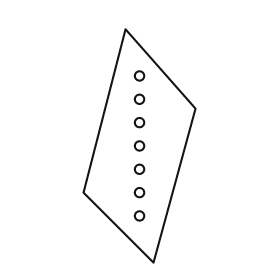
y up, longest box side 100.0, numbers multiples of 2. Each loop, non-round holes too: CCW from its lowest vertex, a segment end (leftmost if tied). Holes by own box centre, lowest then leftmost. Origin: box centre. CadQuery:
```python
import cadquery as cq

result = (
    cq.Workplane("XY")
    .moveTo(6.0, -50.0)
    .lineTo(24.0, 16.0)
    .lineTo(-6.0, 50.0)
    .lineTo(-24.0, -20.0)
    .close()
    .moveTo(0.0, -30.0)
    .circle(2.0)
    .moveTo(0.0, -20.0)
    .circle(2.0)
    .moveTo(0.0, -10.0)
    .circle(2.0)
    .moveTo(0.0, 0.0)
    .circle(2.0)
    .moveTo(0.0, 10.0)
    .circle(2.0)
    .moveTo(0.0, 20.0)
    .circle(2.0)
    .moveTo(0.0, 30.0)
    .circle(2.0)
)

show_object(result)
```